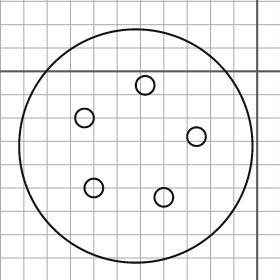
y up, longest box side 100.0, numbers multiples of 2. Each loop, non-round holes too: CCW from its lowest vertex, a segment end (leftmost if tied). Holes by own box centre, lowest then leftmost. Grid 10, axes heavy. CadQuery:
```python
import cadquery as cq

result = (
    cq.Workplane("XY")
    .moveTo(-52.0, -32.0)
    .circle(50.0)
    .moveTo(-40.0, -54.0)
    .circle(4.0)
    .moveTo(-70.0, -50.0)
    .circle(4.0)
    .moveTo(-26.0, -28.0)
    .circle(4.0)
    .moveTo(-74.0, -20.0)
    .circle(4.0)
    .moveTo(-48.0, -6.0)
    .circle(4.0)
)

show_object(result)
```